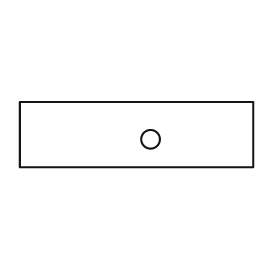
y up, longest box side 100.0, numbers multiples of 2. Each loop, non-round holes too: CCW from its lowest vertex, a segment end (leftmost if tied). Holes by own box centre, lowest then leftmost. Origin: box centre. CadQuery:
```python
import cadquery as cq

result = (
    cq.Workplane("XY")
    .moveTo(-50.0, -14.0)
    .lineTo(50.0, -14.0)
    .lineTo(50.0, 14.0)
    .lineTo(-50.0, 14.0)
    .close()
    .moveTo(6.0, -2.0)
    .circle(4.0)
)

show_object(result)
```